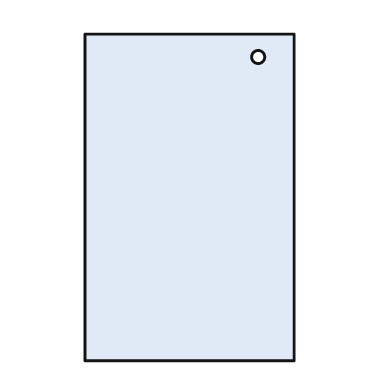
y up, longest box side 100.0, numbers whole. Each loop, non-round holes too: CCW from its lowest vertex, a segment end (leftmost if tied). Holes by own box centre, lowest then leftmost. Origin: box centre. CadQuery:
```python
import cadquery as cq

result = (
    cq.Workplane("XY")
    .moveTo(-32.0, -50.0)
    .lineTo(32.0, -50.0)
    .lineTo(32.0, 50.0)
    .lineTo(-32.0, 50.0)
    .close()
    .moveTo(21.0, 43.0)
    .circle(2.0)
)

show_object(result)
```